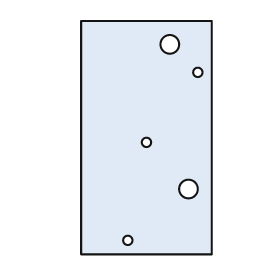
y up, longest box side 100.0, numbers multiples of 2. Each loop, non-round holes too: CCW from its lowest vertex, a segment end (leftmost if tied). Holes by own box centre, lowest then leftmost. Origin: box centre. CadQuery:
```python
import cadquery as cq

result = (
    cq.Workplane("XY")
    .moveTo(-28.0, -50.0)
    .lineTo(28.0, -50.0)
    .lineTo(28.0, 50.0)
    .lineTo(-28.0, 50.0)
    .close()
    .moveTo(-8.0, -44.0)
    .circle(2.0)
    .moveTo(18.0, -22.0)
    .circle(4.0)
    .moveTo(0.0, -2.0)
    .circle(2.0)
    .moveTo(22.0, 28.0)
    .circle(2.0)
    .moveTo(10.0, 40.0)
    .circle(4.0)
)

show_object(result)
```